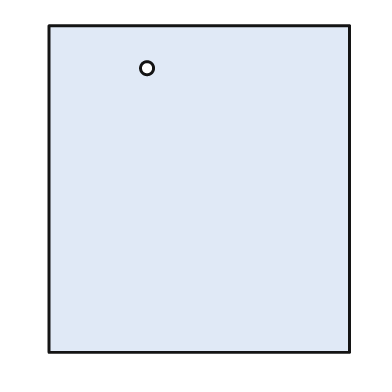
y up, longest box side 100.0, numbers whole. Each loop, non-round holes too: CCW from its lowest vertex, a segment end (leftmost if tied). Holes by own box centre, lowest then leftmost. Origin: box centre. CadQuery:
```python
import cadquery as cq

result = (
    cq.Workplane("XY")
    .moveTo(-46.0, -50.0)
    .lineTo(46.0, -50.0)
    .lineTo(46.0, 50.0)
    .lineTo(-46.0, 50.0)
    .close()
    .moveTo(-16.0, 37.0)
    .circle(2.0)
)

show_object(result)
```